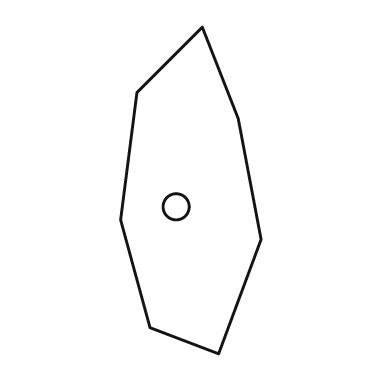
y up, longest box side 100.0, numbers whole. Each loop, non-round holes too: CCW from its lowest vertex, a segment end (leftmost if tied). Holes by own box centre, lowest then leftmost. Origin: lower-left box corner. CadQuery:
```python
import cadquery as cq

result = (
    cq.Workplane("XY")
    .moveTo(30.0, 0.0)
    .lineTo(43.0, 35.0)
    .lineTo(36.0, 72.0)
    .lineTo(25.0, 100.0)
    .lineTo(5.0, 80.0)
    .lineTo(0.0, 41.0)
    .lineTo(9.0, 8.0)
    .close()
    .moveTo(17.0, 45.0)
    .circle(4.0)
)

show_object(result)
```